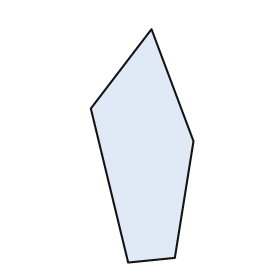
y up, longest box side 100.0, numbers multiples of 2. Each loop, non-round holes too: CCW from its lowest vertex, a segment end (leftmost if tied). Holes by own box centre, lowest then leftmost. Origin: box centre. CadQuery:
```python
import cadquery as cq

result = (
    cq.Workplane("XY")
    .moveTo(-6.0, -50.0)
    .lineTo(14.0, -48.0)
    .lineTo(22.0, 2.0)
    .lineTo(4.0, 50.0)
    .lineTo(-22.0, 16.0)
    .close()
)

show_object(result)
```